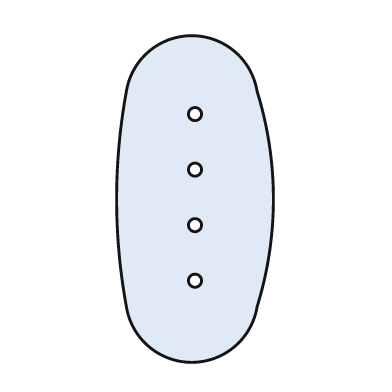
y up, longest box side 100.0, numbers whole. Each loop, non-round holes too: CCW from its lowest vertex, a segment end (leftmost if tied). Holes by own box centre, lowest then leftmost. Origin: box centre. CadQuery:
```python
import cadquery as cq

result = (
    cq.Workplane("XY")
    .moveTo(-21.0, -33.0)
    .threePointArc((-1.0, -50.0), (19.0, -33.0))
    .threePointArc((24.0, 0.0), (19.0, 33.0))
    .threePointArc((-1.0, 50.0), (-21.0, 33.0))
    .threePointArc((-24.0, 0.0), (-21.0, -33.0))
    .close()
    .moveTo(0.0, -25.0)
    .circle(2.0)
    .moveTo(0.0, -8.0)
    .circle(2.0)
    .moveTo(0.0, 9.0)
    .circle(2.0)
    .moveTo(0.0, 26.0)
    .circle(2.0)
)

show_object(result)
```